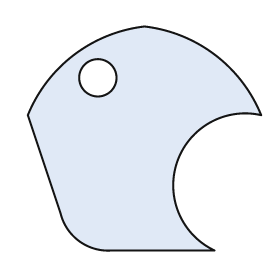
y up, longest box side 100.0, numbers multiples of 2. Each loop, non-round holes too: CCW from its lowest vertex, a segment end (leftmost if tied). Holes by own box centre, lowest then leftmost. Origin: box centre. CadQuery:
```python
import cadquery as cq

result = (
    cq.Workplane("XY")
    .moveTo(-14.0, -48.0)
    .lineTo(30.0, -48.0)
    .threePointArc((14.0, -10.0), (50.0, 10.0))
    .threePointArc((30.0, 36.0), (0.0, 48.0))
    .threePointArc((-30.0, 36.0), (-50.0, 10.0))
    .lineTo(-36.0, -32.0)
    .threePointArc((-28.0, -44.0), (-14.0, -48.0))
    .close()
    .moveTo(-20.0, 26.0)
    .circle(8.0)
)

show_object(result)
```